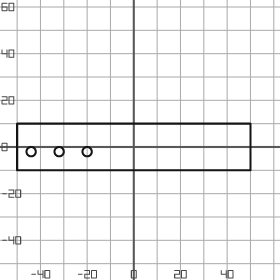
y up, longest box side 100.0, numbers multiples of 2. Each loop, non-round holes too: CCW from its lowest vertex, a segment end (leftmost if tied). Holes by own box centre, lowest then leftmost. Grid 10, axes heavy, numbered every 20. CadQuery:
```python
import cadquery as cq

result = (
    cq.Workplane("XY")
    .moveTo(-50.0, -10.0)
    .lineTo(50.0, -10.0)
    .lineTo(50.0, 10.0)
    .lineTo(-50.0, 10.0)
    .close()
    .moveTo(-44.0, -2.0)
    .circle(2.0)
    .moveTo(-32.0, -2.0)
    .circle(2.0)
    .moveTo(-20.0, -2.0)
    .circle(2.0)
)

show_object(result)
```